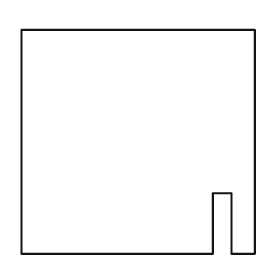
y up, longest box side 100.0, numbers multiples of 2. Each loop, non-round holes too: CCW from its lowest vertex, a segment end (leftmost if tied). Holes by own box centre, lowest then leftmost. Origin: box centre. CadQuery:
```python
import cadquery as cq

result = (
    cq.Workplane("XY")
    .moveTo(-50.0, -48.0)
    .lineTo(32.0, -48.0)
    .lineTo(32.0, -22.0)
    .lineTo(40.0, -22.0)
    .lineTo(40.0, -48.0)
    .lineTo(50.0, -48.0)
    .lineTo(50.0, 48.0)
    .lineTo(-50.0, 48.0)
    .close()
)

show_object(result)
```